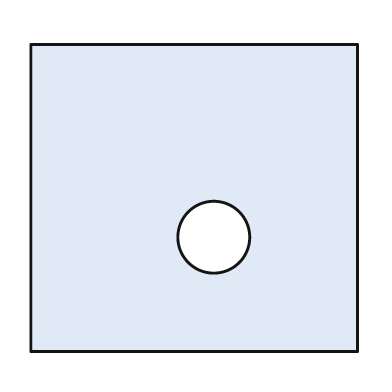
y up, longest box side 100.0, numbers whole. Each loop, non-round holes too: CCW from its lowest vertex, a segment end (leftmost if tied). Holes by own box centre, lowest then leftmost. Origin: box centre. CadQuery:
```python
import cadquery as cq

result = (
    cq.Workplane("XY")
    .moveTo(-50.0, -47.0)
    .lineTo(50.0, -47.0)
    .lineTo(50.0, 47.0)
    .lineTo(-50.0, 47.0)
    .close()
    .moveTo(6.0, -12.0)
    .circle(11.0)
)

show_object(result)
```